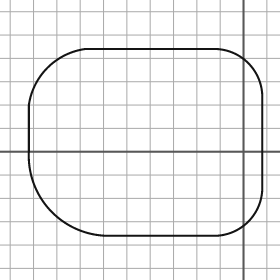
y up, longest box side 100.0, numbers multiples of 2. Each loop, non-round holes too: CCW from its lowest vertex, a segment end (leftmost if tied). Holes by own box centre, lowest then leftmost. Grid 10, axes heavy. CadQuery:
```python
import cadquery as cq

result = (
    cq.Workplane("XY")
    .moveTo(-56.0, -36.0)
    .lineTo(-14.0, -36.0)
    .threePointArc((2.0, -30.0), (8.0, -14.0))
    .lineTo(8.0, 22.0)
    .threePointArc((2.0, 38.0), (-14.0, 44.0))
    .lineTo(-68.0, 44.0)
    .threePointArc((-84.0, 36.0), (-92.0, 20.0))
    .lineTo(-92.0, 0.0)
    .threePointArc((-82.0, -26.0), (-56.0, -36.0))
    .close()
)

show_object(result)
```